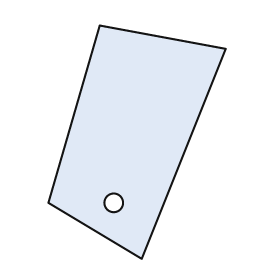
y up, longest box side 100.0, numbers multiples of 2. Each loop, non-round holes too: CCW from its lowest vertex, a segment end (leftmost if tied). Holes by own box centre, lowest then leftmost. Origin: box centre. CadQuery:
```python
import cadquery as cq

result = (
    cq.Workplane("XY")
    .moveTo(2.0, -50.0)
    .lineTo(38.0, 40.0)
    .lineTo(-16.0, 50.0)
    .lineTo(-38.0, -26.0)
    .close()
    .moveTo(-10.0, -26.0)
    .circle(4.0)
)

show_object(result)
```